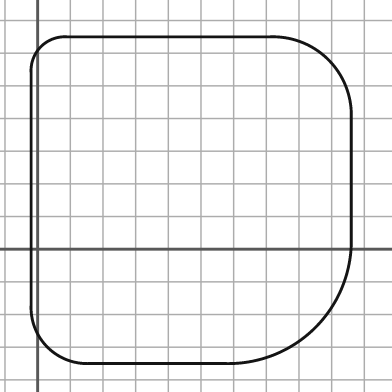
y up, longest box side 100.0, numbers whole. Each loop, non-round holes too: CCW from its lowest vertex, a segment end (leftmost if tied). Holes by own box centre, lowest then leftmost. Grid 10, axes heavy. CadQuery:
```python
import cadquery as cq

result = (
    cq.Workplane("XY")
    .moveTo(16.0, -35.0)
    .lineTo(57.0, -35.0)
    .threePointArc((85.0, -24.0), (96.0, 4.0))
    .lineTo(96.0, 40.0)
    .threePointArc((89.0, 58.0), (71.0, 65.0))
    .lineTo(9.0, 65.0)
    .threePointArc((1.0, 62.0), (-2.0, 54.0))
    .lineTo(-2.0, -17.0)
    .threePointArc((3.0, -30.0), (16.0, -35.0))
    .close()
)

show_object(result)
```